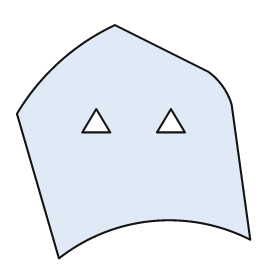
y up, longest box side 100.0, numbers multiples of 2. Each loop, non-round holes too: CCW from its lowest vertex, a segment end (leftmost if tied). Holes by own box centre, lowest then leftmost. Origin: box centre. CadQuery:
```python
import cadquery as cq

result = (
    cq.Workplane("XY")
    .moveTo(-32.0, -50.0)
    .threePointArc((8.0, -34.0), (50.0, -42.0))
    .lineTo(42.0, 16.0)
    .threePointArc((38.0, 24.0), (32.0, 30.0))
    .lineTo(-8.0, 50.0)
    .threePointArc((-32.0, 34.0), (-50.0, 12.0))
    .close()
    .moveTo(-22.0, 4.0)
    .lineTo(-10.0, 4.0)
    .lineTo(-16.0, 14.0)
    .close()
    .moveTo(10.0, 4.0)
    .lineTo(22.0, 4.0)
    .lineTo(16.0, 14.0)
    .close()
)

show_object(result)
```